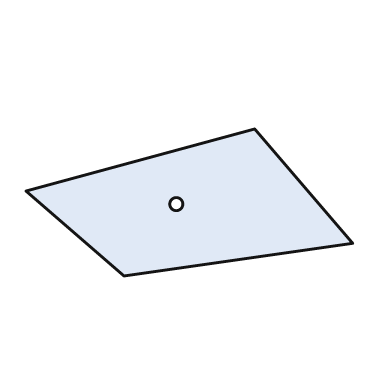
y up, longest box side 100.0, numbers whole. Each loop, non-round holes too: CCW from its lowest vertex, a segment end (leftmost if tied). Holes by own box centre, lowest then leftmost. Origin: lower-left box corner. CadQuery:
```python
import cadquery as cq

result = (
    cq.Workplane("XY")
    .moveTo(30.0, 0.0)
    .lineTo(100.0, 10.0)
    .lineTo(70.0, 45.0)
    .lineTo(0.0, 26.0)
    .close()
    .moveTo(46.0, 22.0)
    .circle(2.0)
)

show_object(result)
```